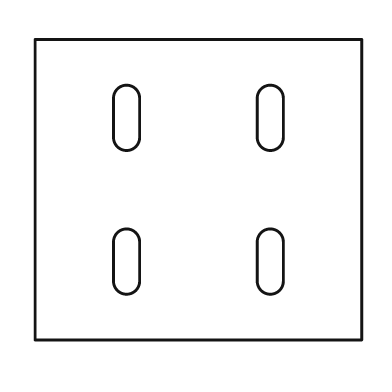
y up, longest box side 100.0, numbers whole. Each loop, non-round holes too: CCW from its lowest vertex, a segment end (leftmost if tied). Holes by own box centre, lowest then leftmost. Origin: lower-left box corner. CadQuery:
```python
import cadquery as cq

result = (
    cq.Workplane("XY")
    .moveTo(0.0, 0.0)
    .lineTo(100.0, 0.0)
    .lineTo(100.0, 92.0)
    .lineTo(0.0, 92.0)
    .close()
    .moveTo(24.0, 18.0)
    .threePointArc((28.0, 14.0), (32.0, 18.0))
    .lineTo(32.0, 30.0)
    .threePointArc((28.0, 34.0), (24.0, 30.0))
    .close()
    .moveTo(68.0, 18.0)
    .threePointArc((72.0, 14.0), (76.0, 18.0))
    .lineTo(76.0, 30.0)
    .threePointArc((72.0, 34.0), (68.0, 30.0))
    .close()
    .moveTo(24.0, 62.0)
    .threePointArc((28.0, 58.0), (32.0, 62.0))
    .lineTo(32.0, 74.0)
    .threePointArc((28.0, 78.0), (24.0, 74.0))
    .close()
    .moveTo(68.0, 62.0)
    .threePointArc((72.0, 58.0), (76.0, 62.0))
    .lineTo(76.0, 74.0)
    .threePointArc((72.0, 78.0), (68.0, 74.0))
    .close()
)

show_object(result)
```